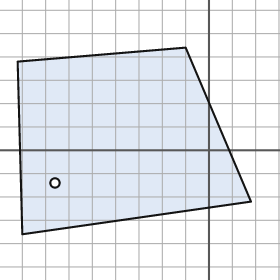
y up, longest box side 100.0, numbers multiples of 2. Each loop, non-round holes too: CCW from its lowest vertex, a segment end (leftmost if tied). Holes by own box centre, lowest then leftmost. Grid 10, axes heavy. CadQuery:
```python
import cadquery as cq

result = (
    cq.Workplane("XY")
    .moveTo(-80.0, -36.0)
    .lineTo(18.0, -22.0)
    .lineTo(-10.0, 44.0)
    .lineTo(-82.0, 38.0)
    .close()
    .moveTo(-66.0, -14.0)
    .circle(2.0)
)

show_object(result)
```